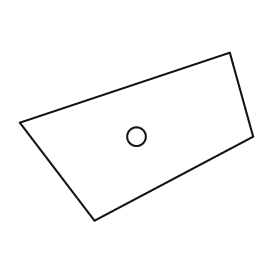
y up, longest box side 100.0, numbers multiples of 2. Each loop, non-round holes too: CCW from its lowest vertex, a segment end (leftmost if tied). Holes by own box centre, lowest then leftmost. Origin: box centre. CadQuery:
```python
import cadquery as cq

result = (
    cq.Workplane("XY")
    .moveTo(-18.0, -36.0)
    .lineTo(50.0, 0.0)
    .lineTo(40.0, 36.0)
    .lineTo(-50.0, 6.0)
    .close()
    .moveTo(0.0, 0.0)
    .circle(4.0)
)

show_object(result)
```